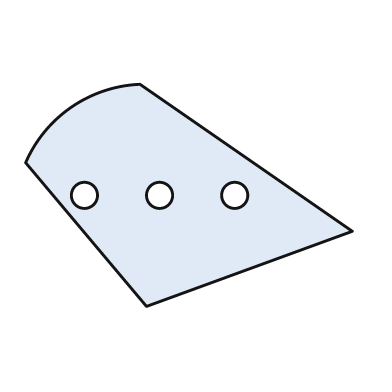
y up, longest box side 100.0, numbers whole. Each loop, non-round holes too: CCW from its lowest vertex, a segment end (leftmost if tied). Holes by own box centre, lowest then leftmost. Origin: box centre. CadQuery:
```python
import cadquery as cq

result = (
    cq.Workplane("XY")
    .moveTo(-13.0, -34.0)
    .lineTo(50.0, -11.0)
    .lineTo(-15.0, 34.0)
    .threePointArc((-36.0, 27.0), (-50.0, 10.0))
    .close()
    .moveTo(-32.0, 0.0)
    .circle(4.0)
    .moveTo(-9.0, 0.0)
    .circle(4.0)
    .moveTo(14.0, 0.0)
    .circle(4.0)
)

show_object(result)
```